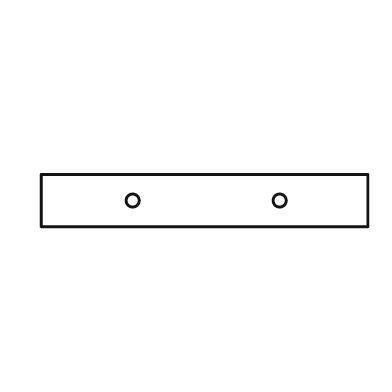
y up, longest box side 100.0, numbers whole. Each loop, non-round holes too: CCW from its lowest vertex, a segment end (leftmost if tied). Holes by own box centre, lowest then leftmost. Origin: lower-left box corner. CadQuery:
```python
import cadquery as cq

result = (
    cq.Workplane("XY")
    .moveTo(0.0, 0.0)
    .lineTo(100.0, 0.0)
    .lineTo(100.0, 16.0)
    .lineTo(0.0, 16.0)
    .close()
    .moveTo(28.0, 8.0)
    .circle(2.0)
    .moveTo(73.0, 8.0)
    .circle(2.0)
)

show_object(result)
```